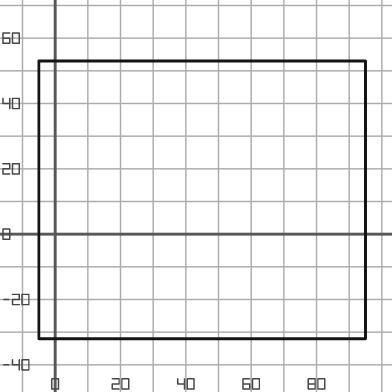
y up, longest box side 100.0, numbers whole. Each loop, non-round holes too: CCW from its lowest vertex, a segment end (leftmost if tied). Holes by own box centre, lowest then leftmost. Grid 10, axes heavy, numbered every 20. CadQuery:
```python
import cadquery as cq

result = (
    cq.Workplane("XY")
    .moveTo(-5.0, -32.0)
    .lineTo(95.0, -32.0)
    .lineTo(95.0, 53.0)
    .lineTo(-5.0, 53.0)
    .close()
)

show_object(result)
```